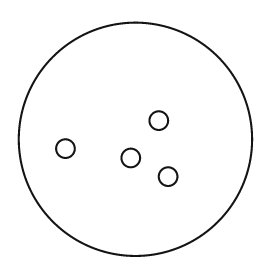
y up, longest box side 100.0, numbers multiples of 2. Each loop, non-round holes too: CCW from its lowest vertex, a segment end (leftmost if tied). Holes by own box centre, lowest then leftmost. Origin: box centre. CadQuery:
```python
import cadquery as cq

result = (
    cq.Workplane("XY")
    .moveTo(0.0, 0.0)
    .circle(50.0)
    .moveTo(14.0, -16.0)
    .circle(4.0)
    .moveTo(-2.0, -8.0)
    .circle(4.0)
    .moveTo(-30.0, -4.0)
    .circle(4.0)
    .moveTo(10.0, 8.0)
    .circle(4.0)
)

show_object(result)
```